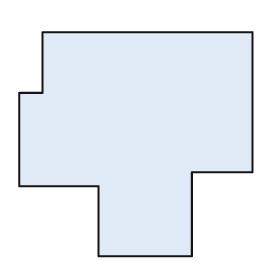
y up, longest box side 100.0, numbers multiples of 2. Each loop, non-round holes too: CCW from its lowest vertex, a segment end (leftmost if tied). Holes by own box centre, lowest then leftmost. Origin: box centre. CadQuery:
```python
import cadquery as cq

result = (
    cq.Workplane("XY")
    .moveTo(-16.0, -48.0)
    .lineTo(24.0, -48.0)
    .lineTo(24.0, -12.0)
    .lineTo(50.0, -12.0)
    .lineTo(50.0, 48.0)
    .lineTo(-40.0, 48.0)
    .lineTo(-40.0, 22.0)
    .lineTo(-50.0, 22.0)
    .lineTo(-50.0, -18.0)
    .lineTo(-16.0, -18.0)
    .close()
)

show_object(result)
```